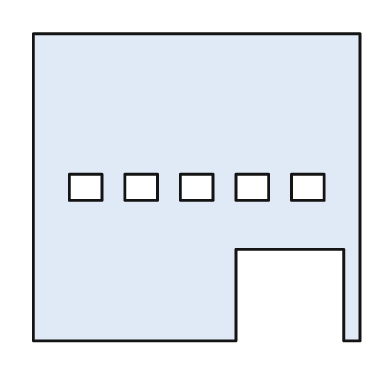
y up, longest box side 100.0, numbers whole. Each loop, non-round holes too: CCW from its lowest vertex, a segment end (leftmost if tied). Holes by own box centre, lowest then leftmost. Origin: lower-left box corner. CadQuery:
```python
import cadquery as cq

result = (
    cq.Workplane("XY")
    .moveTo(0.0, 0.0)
    .lineTo(62.0, 0.0)
    .lineTo(62.0, 28.0)
    .lineTo(95.0, 28.0)
    .lineTo(95.0, 0.0)
    .lineTo(100.0, 0.0)
    .lineTo(100.0, 94.0)
    .lineTo(0.0, 94.0)
    .close()
    .moveTo(11.0, 43.0)
    .lineTo(21.0, 43.0)
    .lineTo(21.0, 51.0)
    .lineTo(11.0, 51.0)
    .close()
    .moveTo(28.0, 43.0)
    .lineTo(38.0, 43.0)
    .lineTo(38.0, 51.0)
    .lineTo(28.0, 51.0)
    .close()
    .moveTo(45.0, 43.0)
    .lineTo(55.0, 43.0)
    .lineTo(55.0, 51.0)
    .lineTo(45.0, 51.0)
    .close()
    .moveTo(62.0, 43.0)
    .lineTo(72.0, 43.0)
    .lineTo(72.0, 51.0)
    .lineTo(62.0, 51.0)
    .close()
    .moveTo(79.0, 43.0)
    .lineTo(89.0, 43.0)
    .lineTo(89.0, 51.0)
    .lineTo(79.0, 51.0)
    .close()
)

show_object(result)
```